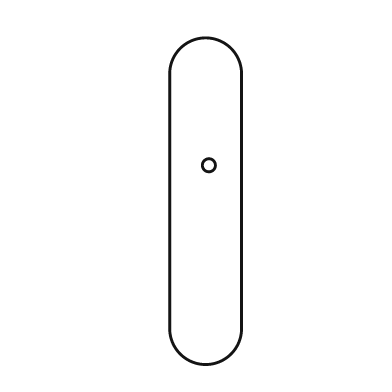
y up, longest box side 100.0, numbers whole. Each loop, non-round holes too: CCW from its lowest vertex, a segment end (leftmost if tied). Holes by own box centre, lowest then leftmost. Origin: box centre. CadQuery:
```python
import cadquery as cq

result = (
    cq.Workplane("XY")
    .moveTo(-11.0, -39.0)
    .threePointArc((0.0, -50.0), (11.0, -39.0))
    .lineTo(11.0, 39.0)
    .threePointArc((0.0, 50.0), (-11.0, 39.0))
    .close()
    .moveTo(1.0, 11.0)
    .circle(2.0)
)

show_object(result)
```